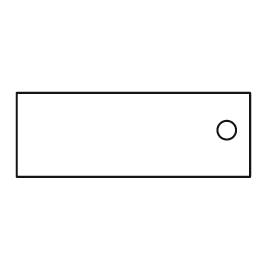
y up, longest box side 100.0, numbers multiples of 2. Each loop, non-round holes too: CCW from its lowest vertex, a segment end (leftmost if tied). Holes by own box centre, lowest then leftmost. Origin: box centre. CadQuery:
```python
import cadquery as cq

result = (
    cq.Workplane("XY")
    .moveTo(-50.0, -18.0)
    .lineTo(50.0, -18.0)
    .lineTo(50.0, 18.0)
    .lineTo(-50.0, 18.0)
    .close()
    .moveTo(40.0, 2.0)
    .circle(4.0)
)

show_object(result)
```